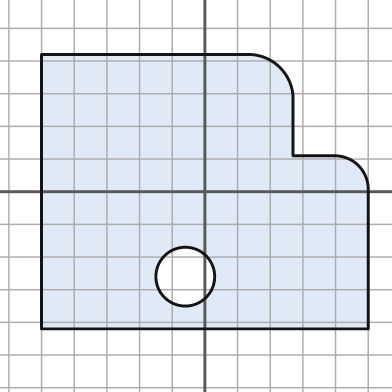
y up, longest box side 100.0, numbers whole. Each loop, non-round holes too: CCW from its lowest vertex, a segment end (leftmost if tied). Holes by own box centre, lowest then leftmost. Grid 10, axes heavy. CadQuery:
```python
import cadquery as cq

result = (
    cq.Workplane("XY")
    .moveTo(-50.0, -42.0)
    .lineTo(50.0, -42.0)
    .lineTo(50.0, 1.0)
    .threePointArc((47.0, 8.0), (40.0, 11.0))
    .lineTo(27.0, 11.0)
    .lineTo(27.0, 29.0)
    .threePointArc((23.0, 38.0), (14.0, 42.0))
    .lineTo(-50.0, 42.0)
    .close()
    .moveTo(-6.0, -26.0)
    .circle(9.0)
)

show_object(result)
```